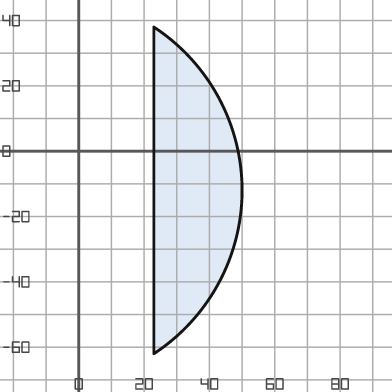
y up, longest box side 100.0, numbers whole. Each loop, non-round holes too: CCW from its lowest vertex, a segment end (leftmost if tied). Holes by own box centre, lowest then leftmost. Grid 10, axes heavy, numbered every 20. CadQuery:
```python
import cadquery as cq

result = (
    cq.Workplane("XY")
    .moveTo(23.0, -62.0)
    .threePointArc((50.0, -12.0), (23.0, 38.0))
    .close()
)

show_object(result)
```